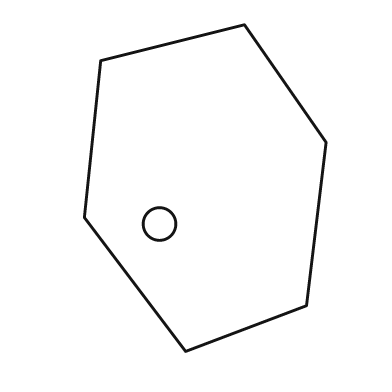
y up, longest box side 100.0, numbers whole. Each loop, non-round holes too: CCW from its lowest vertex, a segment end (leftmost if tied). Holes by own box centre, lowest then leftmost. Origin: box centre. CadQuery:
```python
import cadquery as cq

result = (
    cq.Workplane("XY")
    .moveTo(-6.0, -50.0)
    .lineTo(31.0, -36.0)
    .lineTo(37.0, 14.0)
    .lineTo(12.0, 50.0)
    .lineTo(-32.0, 39.0)
    .lineTo(-37.0, -9.0)
    .close()
    .moveTo(-14.0, -11.0)
    .circle(5.0)
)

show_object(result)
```